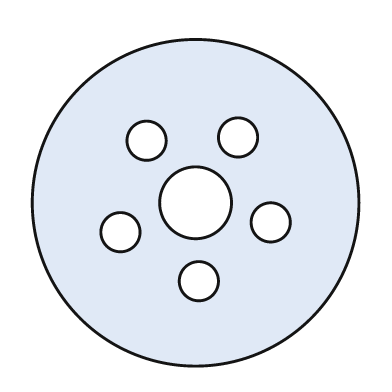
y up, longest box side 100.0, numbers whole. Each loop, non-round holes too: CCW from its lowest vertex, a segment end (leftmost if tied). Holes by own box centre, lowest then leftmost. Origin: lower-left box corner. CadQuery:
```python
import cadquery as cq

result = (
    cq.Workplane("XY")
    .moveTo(50.0, 50.0)
    .circle(50.0)
    .moveTo(51.0, 26.0)
    .circle(6.0)
    .moveTo(27.0, 41.0)
    .circle(6.0)
    .moveTo(73.0, 44.0)
    .circle(6.0)
    .moveTo(50.0, 50.0)
    .circle(11.0)
    .moveTo(35.0, 69.0)
    .circle(6.0)
    .moveTo(63.0, 70.0)
    .circle(6.0)
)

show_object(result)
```